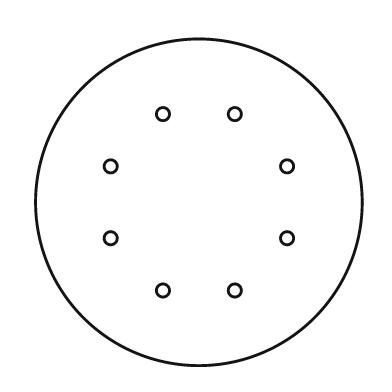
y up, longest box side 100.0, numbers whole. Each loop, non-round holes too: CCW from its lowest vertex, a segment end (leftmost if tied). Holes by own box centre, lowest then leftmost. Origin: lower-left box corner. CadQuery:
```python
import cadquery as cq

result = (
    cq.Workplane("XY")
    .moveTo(50.0, 50.0)
    .circle(50.0)
    .moveTo(39.0, 23.0)
    .circle(2.0)
    .moveTo(61.0, 23.0)
    .circle(2.0)
    .moveTo(23.0, 39.0)
    .circle(2.0)
    .moveTo(77.0, 39.0)
    .circle(2.0)
    .moveTo(23.0, 61.0)
    .circle(2.0)
    .moveTo(77.0, 61.0)
    .circle(2.0)
    .moveTo(39.0, 77.0)
    .circle(2.0)
    .moveTo(61.0, 77.0)
    .circle(2.0)
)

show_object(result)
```